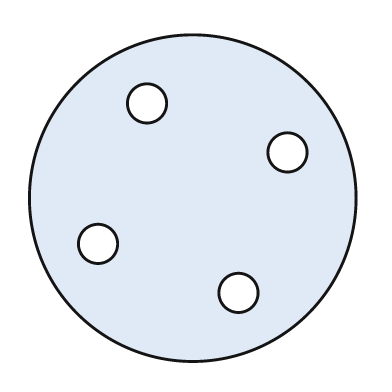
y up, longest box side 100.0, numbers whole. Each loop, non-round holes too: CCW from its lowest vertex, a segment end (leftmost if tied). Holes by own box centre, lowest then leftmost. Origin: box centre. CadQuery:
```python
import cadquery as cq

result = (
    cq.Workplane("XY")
    .moveTo(0.0, 0.0)
    .circle(50.0)
    .moveTo(14.0, -29.0)
    .circle(6.0)
    .moveTo(-29.0, -14.0)
    .circle(6.0)
    .moveTo(29.0, 14.0)
    .circle(6.0)
    .moveTo(-14.0, 29.0)
    .circle(6.0)
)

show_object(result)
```